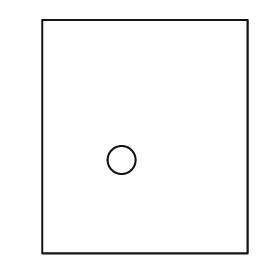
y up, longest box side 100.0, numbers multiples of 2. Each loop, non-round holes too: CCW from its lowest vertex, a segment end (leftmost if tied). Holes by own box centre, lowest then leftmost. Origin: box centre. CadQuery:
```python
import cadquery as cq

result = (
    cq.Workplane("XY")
    .moveTo(-44.0, -50.0)
    .lineTo(44.0, -50.0)
    .lineTo(44.0, 50.0)
    .lineTo(-44.0, 50.0)
    .close()
    .moveTo(-10.0, -10.0)
    .circle(6.0)
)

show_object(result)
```